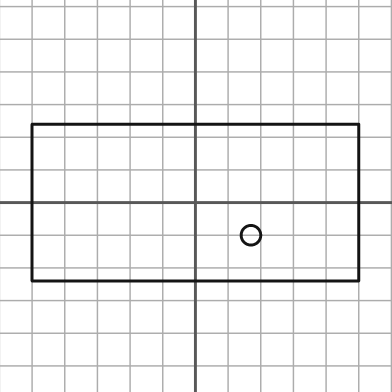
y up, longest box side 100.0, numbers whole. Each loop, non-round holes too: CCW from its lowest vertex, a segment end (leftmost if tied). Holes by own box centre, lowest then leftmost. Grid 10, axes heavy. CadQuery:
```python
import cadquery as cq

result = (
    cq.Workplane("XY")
    .moveTo(-50.0, -24.0)
    .lineTo(50.0, -24.0)
    .lineTo(50.0, 24.0)
    .lineTo(-50.0, 24.0)
    .close()
    .moveTo(17.0, -10.0)
    .circle(3.0)
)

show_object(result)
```